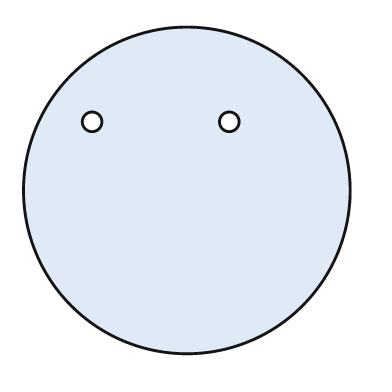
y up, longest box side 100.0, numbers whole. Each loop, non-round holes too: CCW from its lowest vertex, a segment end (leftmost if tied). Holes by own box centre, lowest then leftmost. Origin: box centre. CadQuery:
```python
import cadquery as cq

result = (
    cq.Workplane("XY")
    .moveTo(0.0, 0.0)
    .circle(50.0)
    .moveTo(-29.0, 21.0)
    .circle(3.0)
    .moveTo(13.0, 21.0)
    .circle(3.0)
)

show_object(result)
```